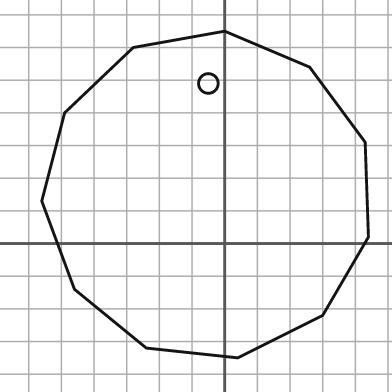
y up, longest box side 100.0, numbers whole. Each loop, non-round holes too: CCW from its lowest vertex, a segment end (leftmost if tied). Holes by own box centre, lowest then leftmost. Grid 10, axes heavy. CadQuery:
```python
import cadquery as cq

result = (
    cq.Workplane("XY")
    .moveTo(4.0, -35.0)
    .lineTo(30.0, -22.0)
    .lineTo(44.0, 2.0)
    .lineTo(43.0, 31.0)
    .lineTo(26.0, 54.0)
    .lineTo(0.0, 65.0)
    .lineTo(-28.0, 60.0)
    .lineTo(-49.0, 40.0)
    .lineTo(-56.0, 13.0)
    .lineTo(-46.0, -14.0)
    .lineTo(-24.0, -32.0)
    .close()
    .moveTo(-5.0, 49.0)
    .circle(3.0)
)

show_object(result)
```